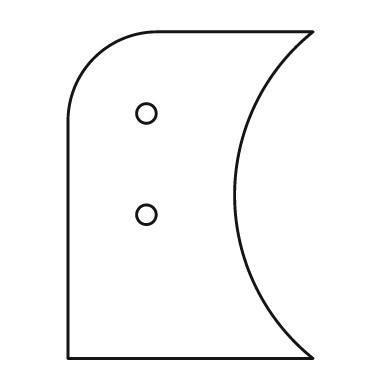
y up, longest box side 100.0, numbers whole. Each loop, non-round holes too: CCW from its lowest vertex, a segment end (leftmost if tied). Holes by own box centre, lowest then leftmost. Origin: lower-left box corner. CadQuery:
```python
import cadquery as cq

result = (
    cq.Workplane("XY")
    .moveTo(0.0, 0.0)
    .lineTo(75.0, 0.0)
    .threePointArc((51.0, 50.0), (75.0, 100.0))
    .lineTo(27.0, 100.0)
    .threePointArc((8.0, 92.0), (0.0, 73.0))
    .close()
    .moveTo(24.0, 44.0)
    .circle(3.0)
    .moveTo(24.0, 75.0)
    .circle(3.0)
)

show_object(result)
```